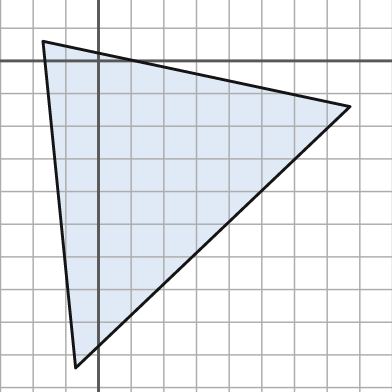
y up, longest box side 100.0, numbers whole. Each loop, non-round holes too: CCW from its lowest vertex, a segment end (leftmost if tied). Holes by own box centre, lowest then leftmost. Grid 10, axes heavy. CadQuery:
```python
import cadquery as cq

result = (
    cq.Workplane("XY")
    .moveTo(-7.0, -94.0)
    .lineTo(77.0, -14.0)
    .lineTo(-17.0, 6.0)
    .close()
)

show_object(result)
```